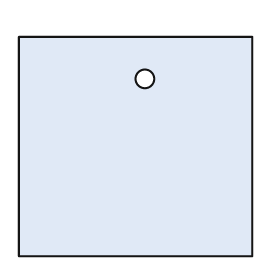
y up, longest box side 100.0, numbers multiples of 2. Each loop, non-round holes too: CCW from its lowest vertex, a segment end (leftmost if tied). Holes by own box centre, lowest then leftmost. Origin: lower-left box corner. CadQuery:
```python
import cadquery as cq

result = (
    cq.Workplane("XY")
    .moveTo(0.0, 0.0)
    .lineTo(100.0, 0.0)
    .lineTo(100.0, 94.0)
    .lineTo(0.0, 94.0)
    .close()
    .moveTo(54.0, 76.0)
    .circle(4.0)
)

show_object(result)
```